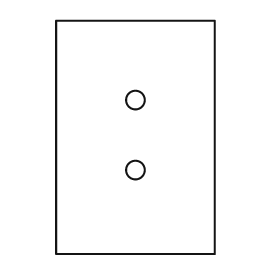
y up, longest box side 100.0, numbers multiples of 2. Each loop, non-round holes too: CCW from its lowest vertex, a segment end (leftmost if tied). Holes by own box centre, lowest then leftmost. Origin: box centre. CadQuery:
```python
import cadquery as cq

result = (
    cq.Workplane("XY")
    .moveTo(-34.0, -50.0)
    .lineTo(34.0, -50.0)
    .lineTo(34.0, 50.0)
    .lineTo(-34.0, 50.0)
    .close()
    .moveTo(0.0, -14.0)
    .circle(4.0)
    .moveTo(0.0, 16.0)
    .circle(4.0)
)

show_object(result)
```